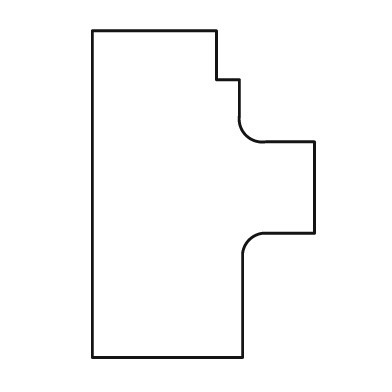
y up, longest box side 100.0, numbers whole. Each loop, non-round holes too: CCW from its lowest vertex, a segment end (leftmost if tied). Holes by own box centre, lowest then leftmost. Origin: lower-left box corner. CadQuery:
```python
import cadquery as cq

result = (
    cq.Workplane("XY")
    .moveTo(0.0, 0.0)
    .lineTo(46.0, 0.0)
    .lineTo(46.0, 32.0)
    .threePointArc((48.0, 36.0), (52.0, 38.0))
    .lineTo(68.0, 38.0)
    .lineTo(68.0, 66.0)
    .lineTo(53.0, 66.0)
    .threePointArc((47.0, 68.0), (45.0, 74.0))
    .lineTo(45.0, 85.0)
    .lineTo(38.0, 85.0)
    .lineTo(38.0, 100.0)
    .lineTo(0.0, 100.0)
    .close()
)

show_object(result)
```